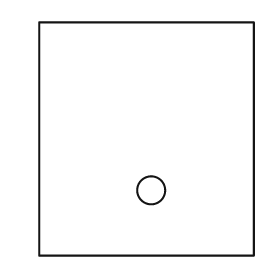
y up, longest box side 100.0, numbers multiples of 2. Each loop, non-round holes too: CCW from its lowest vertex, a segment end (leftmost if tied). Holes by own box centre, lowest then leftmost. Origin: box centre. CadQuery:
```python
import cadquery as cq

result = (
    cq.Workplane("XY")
    .moveTo(-46.0, -50.0)
    .lineTo(46.0, -50.0)
    .lineTo(46.0, 50.0)
    .lineTo(-46.0, 50.0)
    .close()
    .moveTo(2.0, -22.0)
    .circle(6.0)
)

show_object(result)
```